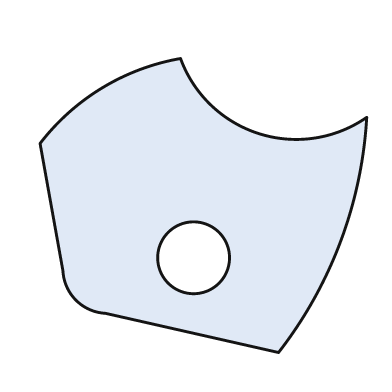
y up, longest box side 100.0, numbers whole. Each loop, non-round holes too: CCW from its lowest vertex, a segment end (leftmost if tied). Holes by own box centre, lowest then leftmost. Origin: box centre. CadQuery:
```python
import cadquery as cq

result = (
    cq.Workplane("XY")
    .moveTo(23.0, -45.0)
    .threePointArc((42.0, -11.0), (50.0, 27.0))
    .threePointArc((17.0, 22.0), (-7.0, 45.0))
    .threePointArc((-31.0, 36.0), (-50.0, 19.0))
    .lineTo(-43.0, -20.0)
    .threePointArc((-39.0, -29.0), (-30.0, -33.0))
    .close()
    .moveTo(-3.0, -16.0)
    .circle(11.0)
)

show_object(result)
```